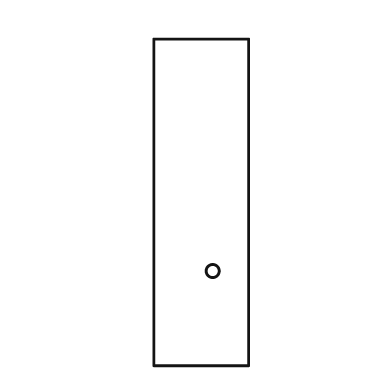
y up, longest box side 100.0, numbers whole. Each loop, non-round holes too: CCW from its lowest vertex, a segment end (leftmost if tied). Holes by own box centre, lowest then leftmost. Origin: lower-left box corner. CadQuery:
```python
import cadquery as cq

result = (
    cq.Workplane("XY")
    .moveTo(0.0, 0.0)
    .lineTo(29.0, 0.0)
    .lineTo(29.0, 100.0)
    .lineTo(0.0, 100.0)
    .close()
    .moveTo(18.0, 29.0)
    .circle(2.0)
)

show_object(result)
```